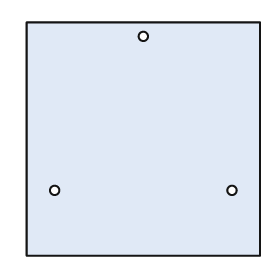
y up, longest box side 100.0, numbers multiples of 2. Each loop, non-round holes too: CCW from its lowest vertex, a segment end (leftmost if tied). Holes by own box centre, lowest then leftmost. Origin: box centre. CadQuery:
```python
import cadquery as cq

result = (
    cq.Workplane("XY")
    .moveTo(-50.0, -50.0)
    .lineTo(50.0, -50.0)
    .lineTo(50.0, 50.0)
    .lineTo(-50.0, 50.0)
    .close()
    .moveTo(-38.0, -22.0)
    .circle(2.0)
    .moveTo(38.0, -22.0)
    .circle(2.0)
    .moveTo(0.0, 44.0)
    .circle(2.0)
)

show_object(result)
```